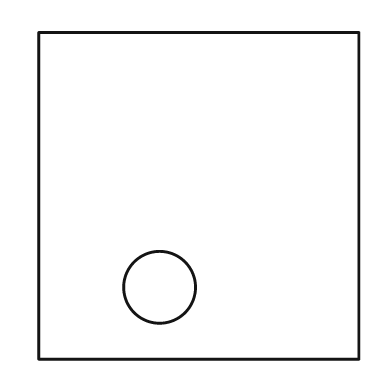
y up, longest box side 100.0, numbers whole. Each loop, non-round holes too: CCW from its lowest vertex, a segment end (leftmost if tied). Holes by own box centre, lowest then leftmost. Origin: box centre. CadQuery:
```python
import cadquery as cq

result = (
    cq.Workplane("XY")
    .moveTo(-49.0, -50.0)
    .lineTo(49.0, -50.0)
    .lineTo(49.0, 50.0)
    .lineTo(-49.0, 50.0)
    .close()
    .moveTo(-12.0, -28.0)
    .circle(11.0)
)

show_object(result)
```